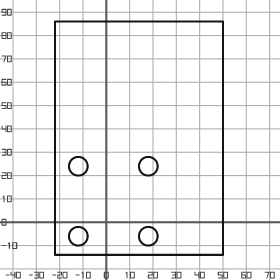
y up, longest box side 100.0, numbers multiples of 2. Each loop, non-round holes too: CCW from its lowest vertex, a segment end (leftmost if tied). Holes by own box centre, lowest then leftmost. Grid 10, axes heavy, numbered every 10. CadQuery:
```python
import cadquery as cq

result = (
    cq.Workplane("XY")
    .moveTo(-22.0, -14.0)
    .lineTo(50.0, -14.0)
    .lineTo(50.0, 86.0)
    .lineTo(-22.0, 86.0)
    .close()
    .moveTo(-12.0, -6.0)
    .circle(4.0)
    .moveTo(18.0, -6.0)
    .circle(4.0)
    .moveTo(-12.0, 24.0)
    .circle(4.0)
    .moveTo(18.0, 24.0)
    .circle(4.0)
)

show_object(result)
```